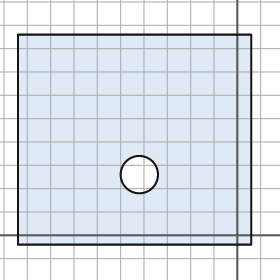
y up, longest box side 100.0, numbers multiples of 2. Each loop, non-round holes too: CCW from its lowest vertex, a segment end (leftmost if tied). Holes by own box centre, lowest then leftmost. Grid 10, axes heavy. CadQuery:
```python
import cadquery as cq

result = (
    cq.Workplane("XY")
    .moveTo(-94.0, -4.0)
    .lineTo(6.0, -4.0)
    .lineTo(6.0, 86.0)
    .lineTo(-94.0, 86.0)
    .close()
    .moveTo(-42.0, 26.0)
    .circle(8.0)
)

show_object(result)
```